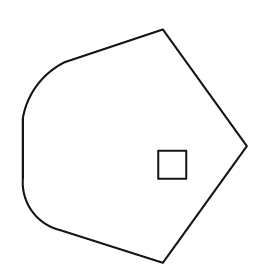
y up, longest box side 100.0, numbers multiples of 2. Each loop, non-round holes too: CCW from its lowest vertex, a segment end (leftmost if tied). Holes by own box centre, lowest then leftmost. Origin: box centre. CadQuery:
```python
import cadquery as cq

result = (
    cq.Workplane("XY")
    .moveTo(12.0, -50.0)
    .lineTo(48.0, 0.0)
    .lineTo(12.0, 50.0)
    .lineTo(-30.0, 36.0)
    .threePointArc((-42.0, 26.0), (-48.0, 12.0))
    .lineTo(-48.0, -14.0)
    .threePointArc((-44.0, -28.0), (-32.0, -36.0))
    .close()
    .moveTo(10.0, -14.0)
    .lineTo(22.0, -14.0)
    .lineTo(22.0, -2.0)
    .lineTo(10.0, -2.0)
    .close()
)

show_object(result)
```